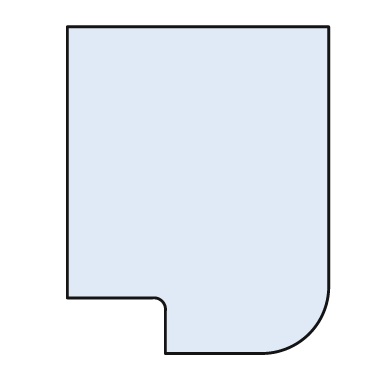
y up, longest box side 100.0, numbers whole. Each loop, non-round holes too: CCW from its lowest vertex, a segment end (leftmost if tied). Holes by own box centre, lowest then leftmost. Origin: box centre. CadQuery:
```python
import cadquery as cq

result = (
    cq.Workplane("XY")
    .moveTo(-10.0, -50.0)
    .lineTo(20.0, -50.0)
    .threePointArc((34.0, -44.0), (40.0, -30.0))
    .lineTo(40.0, 50.0)
    .lineTo(-40.0, 50.0)
    .lineTo(-40.0, -33.0)
    .lineTo(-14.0, -33.0)
    .threePointArc((-11.0, -34.0), (-10.0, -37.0))
    .close()
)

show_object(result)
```